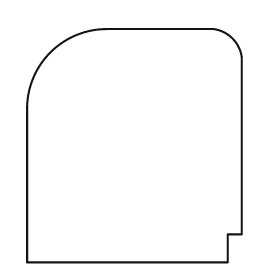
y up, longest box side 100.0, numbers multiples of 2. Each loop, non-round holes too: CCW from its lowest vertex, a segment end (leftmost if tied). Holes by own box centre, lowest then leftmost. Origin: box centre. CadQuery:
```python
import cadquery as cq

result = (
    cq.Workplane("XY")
    .moveTo(-46.0, -50.0)
    .lineTo(40.0, -50.0)
    .lineTo(40.0, -38.0)
    .lineTo(46.0, -38.0)
    .lineTo(46.0, 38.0)
    .threePointArc((42.0, 46.0), (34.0, 50.0))
    .lineTo(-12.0, 50.0)
    .threePointArc((-36.0, 40.0), (-46.0, 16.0))
    .close()
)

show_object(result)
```